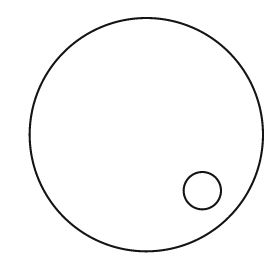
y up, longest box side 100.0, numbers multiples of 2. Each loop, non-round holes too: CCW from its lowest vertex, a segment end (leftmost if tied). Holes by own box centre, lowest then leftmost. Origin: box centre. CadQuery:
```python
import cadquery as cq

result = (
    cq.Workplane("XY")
    .moveTo(0.0, 0.0)
    .circle(50.0)
    .moveTo(24.0, -24.0)
    .circle(8.0)
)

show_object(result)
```